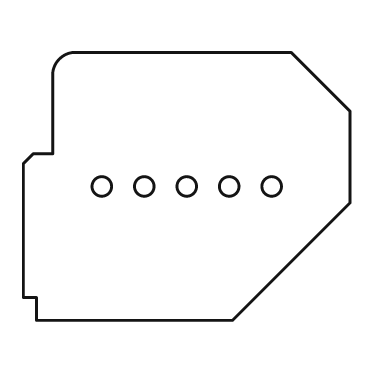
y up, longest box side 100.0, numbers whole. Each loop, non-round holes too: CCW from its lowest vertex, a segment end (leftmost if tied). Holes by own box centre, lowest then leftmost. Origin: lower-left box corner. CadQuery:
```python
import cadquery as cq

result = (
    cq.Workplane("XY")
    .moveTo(4.0, 0.0)
    .lineTo(64.0, 0.0)
    .lineTo(100.0, 36.0)
    .lineTo(100.0, 64.0)
    .lineTo(82.0, 82.0)
    .lineTo(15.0, 82.0)
    .threePointArc((11.0, 80.0), (9.0, 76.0))
    .lineTo(9.0, 51.0)
    .lineTo(3.0, 51.0)
    .lineTo(0.0, 48.0)
    .lineTo(0.0, 7.0)
    .lineTo(4.0, 7.0)
    .close()
    .moveTo(24.0, 41.0)
    .circle(3.0)
    .moveTo(37.0, 41.0)
    .circle(3.0)
    .moveTo(50.0, 41.0)
    .circle(3.0)
    .moveTo(63.0, 41.0)
    .circle(3.0)
    .moveTo(76.0, 41.0)
    .circle(3.0)
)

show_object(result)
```